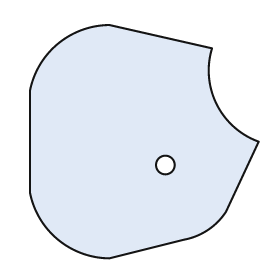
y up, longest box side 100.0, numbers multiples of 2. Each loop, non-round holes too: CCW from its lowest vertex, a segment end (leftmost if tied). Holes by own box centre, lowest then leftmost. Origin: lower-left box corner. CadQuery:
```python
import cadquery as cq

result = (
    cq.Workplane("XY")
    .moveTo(34.0, 0.0)
    .lineTo(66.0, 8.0)
    .threePointArc((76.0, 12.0), (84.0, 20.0))
    .lineTo(98.0, 50.0)
    .threePointArc((80.0, 66.0), (78.0, 90.0))
    .lineTo(34.0, 100.0)
    .threePointArc((12.0, 92.0), (0.0, 72.0))
    .lineTo(0.0, 28.0)
    .threePointArc((12.0, 8.0), (34.0, 0.0))
    .close()
    .moveTo(58.0, 40.0)
    .circle(4.0)
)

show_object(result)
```